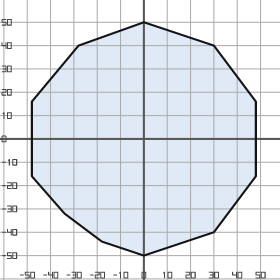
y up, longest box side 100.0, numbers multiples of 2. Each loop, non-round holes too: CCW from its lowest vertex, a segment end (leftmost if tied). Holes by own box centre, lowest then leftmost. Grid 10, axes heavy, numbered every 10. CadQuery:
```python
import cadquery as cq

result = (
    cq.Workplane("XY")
    .moveTo(0.0, -50.0)
    .lineTo(30.0, -40.0)
    .lineTo(48.0, -16.0)
    .lineTo(48.0, 16.0)
    .lineTo(30.0, 40.0)
    .lineTo(0.0, 50.0)
    .lineTo(-28.0, 40.0)
    .lineTo(-48.0, 16.0)
    .lineTo(-48.0, -16.0)
    .lineTo(-34.0, -32.0)
    .lineTo(-18.0, -44.0)
    .close()
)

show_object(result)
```